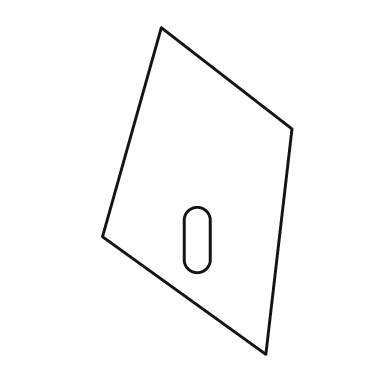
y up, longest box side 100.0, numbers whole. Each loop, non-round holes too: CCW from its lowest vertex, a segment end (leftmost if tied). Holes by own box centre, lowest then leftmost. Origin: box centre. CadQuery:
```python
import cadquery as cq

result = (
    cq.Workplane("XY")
    .moveTo(21.0, -50.0)
    .lineTo(29.0, 19.0)
    .lineTo(-11.0, 50.0)
    .lineTo(-29.0, -14.0)
    .close()
    .moveTo(-4.0, -21.0)
    .threePointArc((0.0, -25.0), (4.0, -21.0))
    .lineTo(4.0, -9.0)
    .threePointArc((0.0, -5.0), (-4.0, -9.0))
    .close()
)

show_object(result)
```